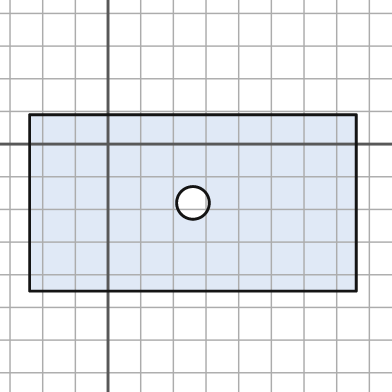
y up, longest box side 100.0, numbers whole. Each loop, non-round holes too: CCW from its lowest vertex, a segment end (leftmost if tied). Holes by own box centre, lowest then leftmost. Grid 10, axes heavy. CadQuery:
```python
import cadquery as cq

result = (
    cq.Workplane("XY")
    .moveTo(-24.0, -45.0)
    .lineTo(76.0, -45.0)
    .lineTo(76.0, 9.0)
    .lineTo(-24.0, 9.0)
    .close()
    .moveTo(26.0, -18.0)
    .circle(5.0)
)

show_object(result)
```